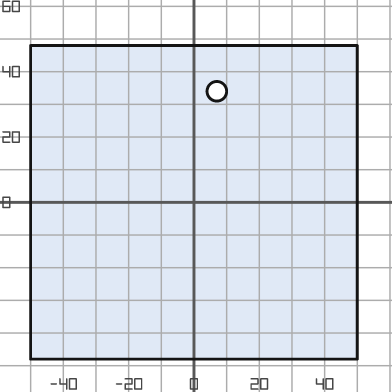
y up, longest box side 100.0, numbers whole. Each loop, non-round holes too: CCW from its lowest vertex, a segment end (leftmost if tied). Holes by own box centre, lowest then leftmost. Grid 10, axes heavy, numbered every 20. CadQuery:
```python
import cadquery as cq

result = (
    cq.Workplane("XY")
    .moveTo(-50.0, -48.0)
    .lineTo(50.0, -48.0)
    .lineTo(50.0, 48.0)
    .lineTo(-50.0, 48.0)
    .close()
    .moveTo(7.0, 34.0)
    .circle(3.0)
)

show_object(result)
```